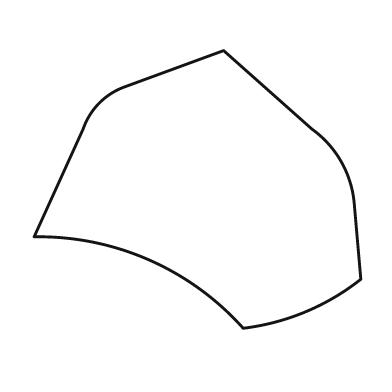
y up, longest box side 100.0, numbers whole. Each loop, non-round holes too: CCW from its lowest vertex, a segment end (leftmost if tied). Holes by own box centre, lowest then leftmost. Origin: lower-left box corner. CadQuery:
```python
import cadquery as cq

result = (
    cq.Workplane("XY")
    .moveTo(64.0, 0.0)
    .threePointArc((83.0, 5.0), (100.0, 15.0))
    .lineTo(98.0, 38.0)
    .threePointArc((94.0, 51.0), (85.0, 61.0))
    .lineTo(58.0, 85.0)
    .lineTo(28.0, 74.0)
    .threePointArc((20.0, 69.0), (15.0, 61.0))
    .lineTo(0.0, 28.0)
    .threePointArc((35.0, 21.0), (64.0, 0.0))
    .close()
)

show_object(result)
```